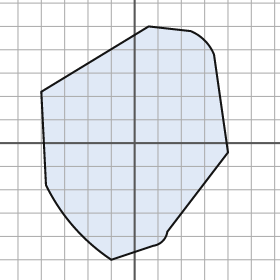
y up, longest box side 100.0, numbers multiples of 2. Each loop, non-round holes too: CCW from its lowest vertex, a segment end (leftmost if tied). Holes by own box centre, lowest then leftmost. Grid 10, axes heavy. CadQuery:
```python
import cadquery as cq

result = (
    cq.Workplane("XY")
    .moveTo(-10.0, -50.0)
    .lineTo(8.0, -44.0)
    .threePointArc((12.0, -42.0), (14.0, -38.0))
    .lineTo(40.0, -4.0)
    .lineTo(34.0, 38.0)
    .threePointArc((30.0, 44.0), (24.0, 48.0))
    .lineTo(6.0, 50.0)
    .lineTo(-40.0, 22.0)
    .lineTo(-38.0, -18.0)
    .threePointArc((-26.0, -36.0), (-10.0, -50.0))
    .close()
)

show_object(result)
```